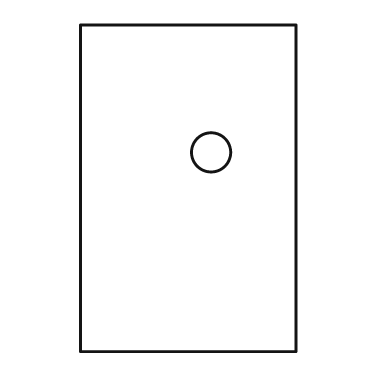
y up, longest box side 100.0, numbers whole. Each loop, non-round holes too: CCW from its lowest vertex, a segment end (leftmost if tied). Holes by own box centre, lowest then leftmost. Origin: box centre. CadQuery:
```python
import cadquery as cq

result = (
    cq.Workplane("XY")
    .moveTo(-33.0, -50.0)
    .lineTo(33.0, -50.0)
    .lineTo(33.0, 50.0)
    .lineTo(-33.0, 50.0)
    .close()
    .moveTo(7.0, 11.0)
    .circle(6.0)
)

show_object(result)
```